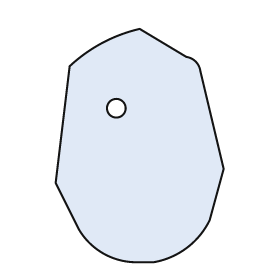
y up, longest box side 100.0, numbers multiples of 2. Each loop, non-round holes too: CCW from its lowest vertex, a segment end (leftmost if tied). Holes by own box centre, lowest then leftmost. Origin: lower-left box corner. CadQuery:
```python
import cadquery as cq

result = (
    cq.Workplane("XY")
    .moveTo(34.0, 0.0)
    .lineTo(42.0, 0.0)
    .threePointArc((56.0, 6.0), (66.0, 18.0))
    .lineTo(72.0, 40.0)
    .lineTo(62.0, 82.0)
    .threePointArc((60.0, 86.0), (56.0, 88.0))
    .lineTo(36.0, 100.0)
    .threePointArc((20.0, 94.0), (6.0, 84.0))
    .lineTo(0.0, 34.0)
    .lineTo(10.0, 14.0)
    .threePointArc((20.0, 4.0), (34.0, 0.0))
    .close()
    .moveTo(26.0, 66.0)
    .circle(4.0)
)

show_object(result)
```